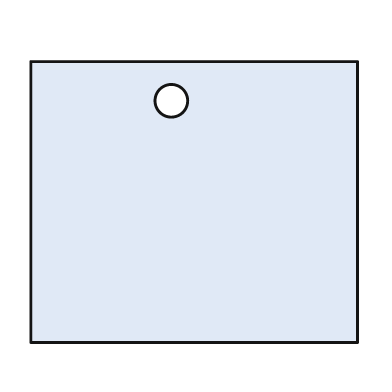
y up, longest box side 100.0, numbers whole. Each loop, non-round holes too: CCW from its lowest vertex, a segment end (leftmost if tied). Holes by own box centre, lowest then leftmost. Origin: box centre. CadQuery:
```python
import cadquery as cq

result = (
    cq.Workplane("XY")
    .moveTo(-50.0, -43.0)
    .lineTo(50.0, -43.0)
    .lineTo(50.0, 43.0)
    .lineTo(-50.0, 43.0)
    .close()
    .moveTo(-7.0, 31.0)
    .circle(5.0)
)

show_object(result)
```